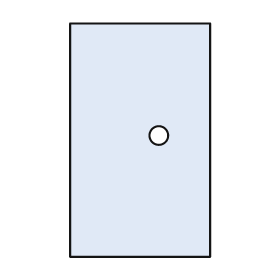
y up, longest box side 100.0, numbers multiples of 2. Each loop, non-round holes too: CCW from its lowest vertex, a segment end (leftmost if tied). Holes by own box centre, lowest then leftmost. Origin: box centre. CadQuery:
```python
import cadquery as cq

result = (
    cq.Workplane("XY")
    .moveTo(-30.0, -50.0)
    .lineTo(30.0, -50.0)
    .lineTo(30.0, 50.0)
    .lineTo(-30.0, 50.0)
    .close()
    .moveTo(8.0, 2.0)
    .circle(4.0)
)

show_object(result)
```